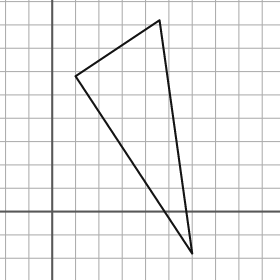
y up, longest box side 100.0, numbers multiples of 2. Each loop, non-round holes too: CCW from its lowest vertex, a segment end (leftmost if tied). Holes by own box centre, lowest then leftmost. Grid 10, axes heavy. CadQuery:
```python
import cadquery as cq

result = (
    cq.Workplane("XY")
    .moveTo(60.0, -18.0)
    .lineTo(46.0, 82.0)
    .lineTo(10.0, 58.0)
    .close()
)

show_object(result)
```